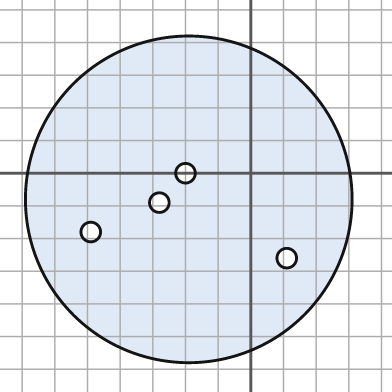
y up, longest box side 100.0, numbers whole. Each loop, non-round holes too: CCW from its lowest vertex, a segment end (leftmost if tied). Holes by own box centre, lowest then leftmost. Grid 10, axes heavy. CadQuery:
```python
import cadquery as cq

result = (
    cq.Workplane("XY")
    .moveTo(-19.0, -8.0)
    .circle(50.0)
    .moveTo(11.0, -26.0)
    .circle(3.0)
    .moveTo(-49.0, -18.0)
    .circle(3.0)
    .moveTo(-28.0, -9.0)
    .circle(3.0)
    .moveTo(-20.0, 0.0)
    .circle(3.0)
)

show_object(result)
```